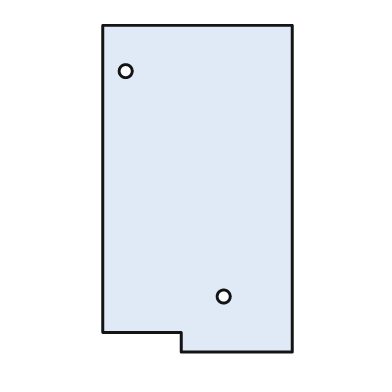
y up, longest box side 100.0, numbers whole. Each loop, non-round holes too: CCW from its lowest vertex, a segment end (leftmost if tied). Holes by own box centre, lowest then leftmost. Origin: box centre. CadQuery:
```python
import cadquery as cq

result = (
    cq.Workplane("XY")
    .moveTo(-5.0, -50.0)
    .lineTo(29.0, -50.0)
    .lineTo(29.0, 50.0)
    .lineTo(-29.0, 50.0)
    .lineTo(-29.0, -44.0)
    .lineTo(-5.0, -44.0)
    .close()
    .moveTo(8.0, -33.0)
    .circle(2.0)
    .moveTo(-22.0, 36.0)
    .circle(2.0)
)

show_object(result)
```